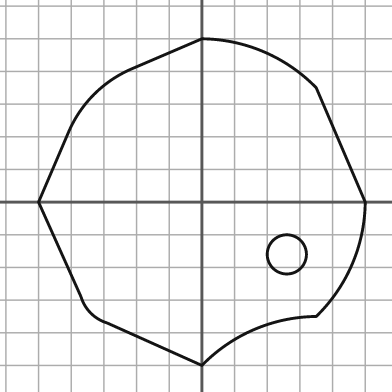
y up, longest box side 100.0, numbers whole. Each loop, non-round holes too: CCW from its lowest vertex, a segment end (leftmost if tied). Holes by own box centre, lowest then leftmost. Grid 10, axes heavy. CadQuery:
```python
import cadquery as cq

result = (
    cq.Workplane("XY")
    .moveTo(0.0, -50.0)
    .threePointArc((16.0, -39.0), (35.0, -35.0))
    .threePointArc((46.0, -19.0), (50.0, 0.0))
    .lineTo(35.0, 35.0)
    .threePointArc((19.0, 46.0), (0.0, 50.0))
    .lineTo(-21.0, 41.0)
    .threePointArc((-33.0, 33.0), (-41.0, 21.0))
    .lineTo(-50.0, 0.0)
    .lineTo(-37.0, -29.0)
    .threePointArc((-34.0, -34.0), (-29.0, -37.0))
    .close()
    .moveTo(26.0, -16.0)
    .circle(6.0)
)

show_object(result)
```